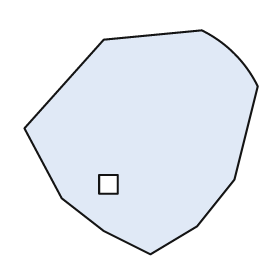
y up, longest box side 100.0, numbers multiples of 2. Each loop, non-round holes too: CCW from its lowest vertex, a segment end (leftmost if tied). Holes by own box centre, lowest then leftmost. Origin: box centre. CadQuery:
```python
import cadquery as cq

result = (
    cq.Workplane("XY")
    .moveTo(4.0, -48.0)
    .lineTo(24.0, -36.0)
    .lineTo(40.0, -16.0)
    .lineTo(50.0, 24.0)
    .threePointArc((40.0, 38.0), (26.0, 48.0))
    .lineTo(-16.0, 44.0)
    .lineTo(-50.0, 6.0)
    .lineTo(-34.0, -24.0)
    .lineTo(-16.0, -38.0)
    .close()
    .moveTo(-18.0, -22.0)
    .lineTo(-10.0, -22.0)
    .lineTo(-10.0, -14.0)
    .lineTo(-18.0, -14.0)
    .close()
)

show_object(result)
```